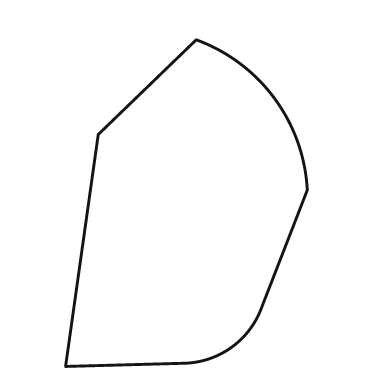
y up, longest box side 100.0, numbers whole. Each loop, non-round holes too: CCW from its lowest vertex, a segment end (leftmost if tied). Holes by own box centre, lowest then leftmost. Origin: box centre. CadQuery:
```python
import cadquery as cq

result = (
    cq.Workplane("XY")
    .moveTo(-37.0, -50.0)
    .lineTo(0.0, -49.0)
    .threePointArc((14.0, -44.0), (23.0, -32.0))
    .lineTo(37.0, 4.0)
    .threePointArc((27.0, 32.0), (3.0, 50.0))
    .lineTo(-27.0, 21.0)
    .close()
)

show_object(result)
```